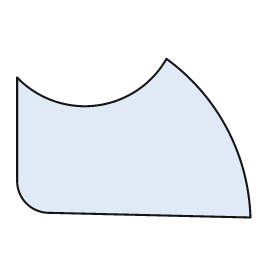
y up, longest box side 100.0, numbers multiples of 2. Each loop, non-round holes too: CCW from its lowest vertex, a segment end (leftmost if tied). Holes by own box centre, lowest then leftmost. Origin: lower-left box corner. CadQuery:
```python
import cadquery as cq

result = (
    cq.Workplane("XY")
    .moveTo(100.0, 0.0)
    .threePointArc((90.0, 38.0), (64.0, 68.0))
    .threePointArc((34.0, 48.0), (0.0, 60.0))
    .lineTo(0.0, 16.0)
    .threePointArc((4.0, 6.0), (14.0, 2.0))
    .close()
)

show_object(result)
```